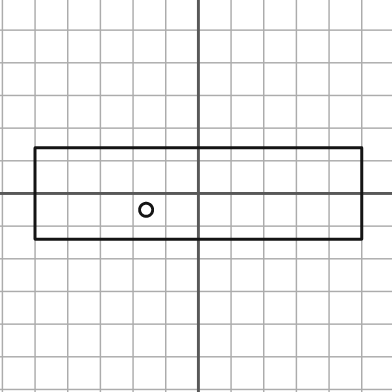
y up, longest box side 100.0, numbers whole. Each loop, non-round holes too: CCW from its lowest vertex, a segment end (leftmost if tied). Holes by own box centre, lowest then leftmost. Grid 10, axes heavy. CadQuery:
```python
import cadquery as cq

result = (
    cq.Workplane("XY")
    .moveTo(-50.0, -14.0)
    .lineTo(50.0, -14.0)
    .lineTo(50.0, 14.0)
    .lineTo(-50.0, 14.0)
    .close()
    .moveTo(-16.0, -5.0)
    .circle(2.0)
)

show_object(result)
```